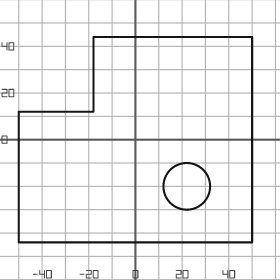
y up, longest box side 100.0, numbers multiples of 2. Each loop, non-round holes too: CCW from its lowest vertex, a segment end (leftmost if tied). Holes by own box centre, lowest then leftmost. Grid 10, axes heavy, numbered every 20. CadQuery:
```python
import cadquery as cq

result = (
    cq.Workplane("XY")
    .moveTo(-50.0, -44.0)
    .lineTo(50.0, -44.0)
    .lineTo(50.0, 44.0)
    .lineTo(-18.0, 44.0)
    .lineTo(-18.0, 12.0)
    .lineTo(-50.0, 12.0)
    .close()
    .moveTo(22.0, -20.0)
    .circle(10.0)
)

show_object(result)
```